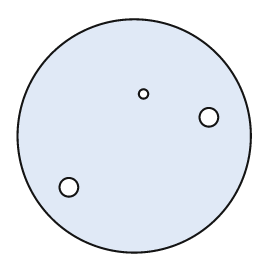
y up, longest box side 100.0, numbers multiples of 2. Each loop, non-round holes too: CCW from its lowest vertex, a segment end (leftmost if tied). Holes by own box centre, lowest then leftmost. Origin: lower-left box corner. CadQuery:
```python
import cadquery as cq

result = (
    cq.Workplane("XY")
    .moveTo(50.0, 50.0)
    .circle(50.0)
    .moveTo(22.0, 28.0)
    .circle(4.0)
    .moveTo(82.0, 58.0)
    .circle(4.0)
    .moveTo(54.0, 68.0)
    .circle(2.0)
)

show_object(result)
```